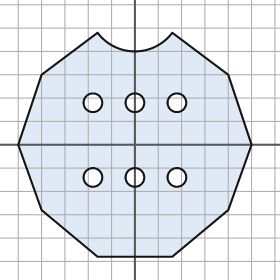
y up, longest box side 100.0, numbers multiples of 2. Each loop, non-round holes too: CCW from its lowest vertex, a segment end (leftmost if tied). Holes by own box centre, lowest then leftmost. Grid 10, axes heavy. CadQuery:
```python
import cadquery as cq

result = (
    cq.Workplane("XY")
    .moveTo(-16.0, -48.0)
    .lineTo(16.0, -48.0)
    .lineTo(40.0, -28.0)
    .lineTo(50.0, 0.0)
    .lineTo(40.0, 30.0)
    .lineTo(16.0, 48.0)
    .threePointArc((0.0, 40.0), (-16.0, 48.0))
    .lineTo(-40.0, 30.0)
    .lineTo(-50.0, 0.0)
    .lineTo(-40.0, -28.0)
    .close()
    .moveTo(-18.0, -14.0)
    .circle(4.0)
    .moveTo(0.0, -14.0)
    .circle(4.0)
    .moveTo(18.0, -14.0)
    .circle(4.0)
    .moveTo(-18.0, 18.0)
    .circle(4.0)
    .moveTo(0.0, 18.0)
    .circle(4.0)
    .moveTo(18.0, 18.0)
    .circle(4.0)
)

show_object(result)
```